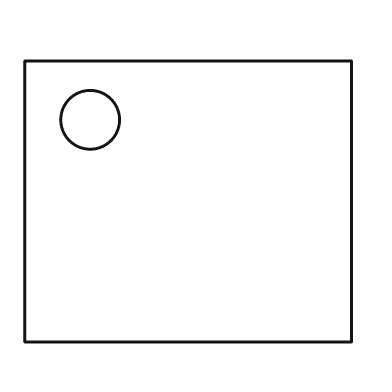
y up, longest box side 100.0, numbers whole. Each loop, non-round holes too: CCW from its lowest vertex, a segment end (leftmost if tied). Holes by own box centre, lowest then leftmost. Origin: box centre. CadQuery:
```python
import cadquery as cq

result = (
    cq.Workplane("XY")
    .moveTo(-50.0, -43.0)
    .lineTo(50.0, -43.0)
    .lineTo(50.0, 43.0)
    .lineTo(-50.0, 43.0)
    .close()
    .moveTo(-30.0, 25.0)
    .circle(9.0)
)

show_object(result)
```